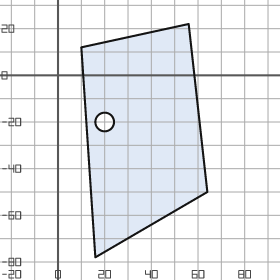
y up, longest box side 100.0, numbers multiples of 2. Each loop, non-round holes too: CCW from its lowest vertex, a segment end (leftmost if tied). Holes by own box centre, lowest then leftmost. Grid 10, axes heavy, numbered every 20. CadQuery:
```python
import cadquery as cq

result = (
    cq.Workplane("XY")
    .moveTo(16.0, -78.0)
    .lineTo(64.0, -50.0)
    .lineTo(56.0, 22.0)
    .lineTo(10.0, 12.0)
    .close()
    .moveTo(20.0, -20.0)
    .circle(4.0)
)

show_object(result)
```